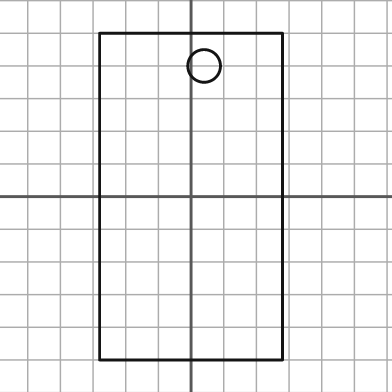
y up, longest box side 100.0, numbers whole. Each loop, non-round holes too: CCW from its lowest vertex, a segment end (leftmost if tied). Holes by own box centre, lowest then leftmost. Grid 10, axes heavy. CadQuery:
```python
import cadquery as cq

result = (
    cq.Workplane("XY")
    .moveTo(-28.0, -50.0)
    .lineTo(28.0, -50.0)
    .lineTo(28.0, 50.0)
    .lineTo(-28.0, 50.0)
    .close()
    .moveTo(4.0, 40.0)
    .circle(5.0)
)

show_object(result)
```